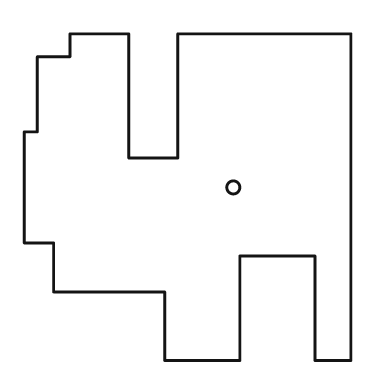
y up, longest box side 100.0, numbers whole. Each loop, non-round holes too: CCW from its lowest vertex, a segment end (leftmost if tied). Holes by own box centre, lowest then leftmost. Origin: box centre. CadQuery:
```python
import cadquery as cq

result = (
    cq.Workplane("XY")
    .moveTo(-7.0, -50.0)
    .lineTo(16.0, -50.0)
    .lineTo(16.0, -18.0)
    .lineTo(39.0, -18.0)
    .lineTo(39.0, -50.0)
    .lineTo(50.0, -50.0)
    .lineTo(50.0, 50.0)
    .lineTo(-3.0, 50.0)
    .lineTo(-3.0, 12.0)
    .lineTo(-18.0, 12.0)
    .lineTo(-18.0, 50.0)
    .lineTo(-36.0, 50.0)
    .lineTo(-36.0, 43.0)
    .lineTo(-46.0, 43.0)
    .lineTo(-46.0, 20.0)
    .lineTo(-50.0, 20.0)
    .lineTo(-50.0, -14.0)
    .lineTo(-41.0, -14.0)
    .lineTo(-41.0, -29.0)
    .lineTo(-7.0, -29.0)
    .close()
    .moveTo(14.0, 3.0)
    .circle(2.0)
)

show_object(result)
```